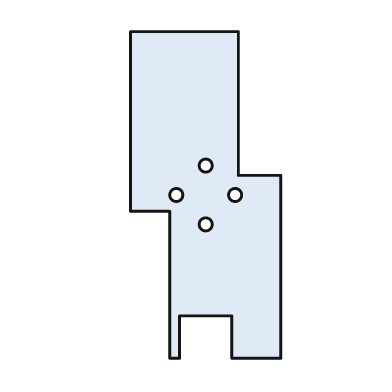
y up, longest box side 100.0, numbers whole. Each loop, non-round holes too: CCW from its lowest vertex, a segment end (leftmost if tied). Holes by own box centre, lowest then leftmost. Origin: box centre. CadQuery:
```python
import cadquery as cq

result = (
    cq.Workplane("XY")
    .moveTo(-11.0, -50.0)
    .lineTo(-8.0, -50.0)
    .lineTo(-8.0, -37.0)
    .lineTo(8.0, -37.0)
    .lineTo(8.0, -50.0)
    .lineTo(23.0, -50.0)
    .lineTo(23.0, 6.0)
    .lineTo(10.0, 6.0)
    .lineTo(10.0, 50.0)
    .lineTo(-23.0, 50.0)
    .lineTo(-23.0, -5.0)
    .lineTo(-11.0, -5.0)
    .close()
    .moveTo(0.0, -9.0)
    .circle(2.0)
    .moveTo(-9.0, 0.0)
    .circle(2.0)
    .moveTo(9.0, 0.0)
    .circle(2.0)
    .moveTo(0.0, 9.0)
    .circle(2.0)
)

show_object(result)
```